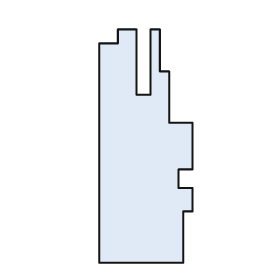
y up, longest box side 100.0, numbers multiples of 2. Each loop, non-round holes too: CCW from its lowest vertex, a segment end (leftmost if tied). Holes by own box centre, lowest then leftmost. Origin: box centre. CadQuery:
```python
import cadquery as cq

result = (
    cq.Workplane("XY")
    .moveTo(-20.0, -50.0)
    .lineTo(16.0, -50.0)
    .lineTo(16.0, -28.0)
    .lineTo(20.0, -28.0)
    .lineTo(20.0, -18.0)
    .lineTo(14.0, -18.0)
    .lineTo(14.0, -10.0)
    .lineTo(20.0, -10.0)
    .lineTo(20.0, 10.0)
    .lineTo(10.0, 10.0)
    .lineTo(10.0, 32.0)
    .lineTo(6.0, 32.0)
    .lineTo(6.0, 50.0)
    .lineTo(2.0, 50.0)
    .lineTo(2.0, 22.0)
    .lineTo(-4.0, 22.0)
    .lineTo(-4.0, 50.0)
    .lineTo(-12.0, 50.0)
    .lineTo(-12.0, 44.0)
    .lineTo(-20.0, 44.0)
    .close()
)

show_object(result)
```